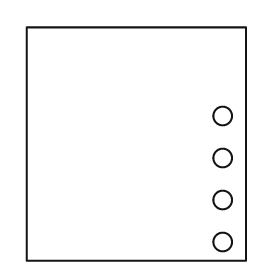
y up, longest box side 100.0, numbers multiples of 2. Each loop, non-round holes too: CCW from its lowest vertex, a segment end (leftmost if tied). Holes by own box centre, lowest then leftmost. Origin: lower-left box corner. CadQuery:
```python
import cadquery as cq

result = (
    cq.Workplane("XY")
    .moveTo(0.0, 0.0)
    .lineTo(94.0, 0.0)
    .lineTo(94.0, 100.0)
    .lineTo(0.0, 100.0)
    .close()
    .moveTo(84.0, 8.0)
    .circle(4.0)
    .moveTo(84.0, 26.0)
    .circle(4.0)
    .moveTo(84.0, 44.0)
    .circle(4.0)
    .moveTo(84.0, 62.0)
    .circle(4.0)
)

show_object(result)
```